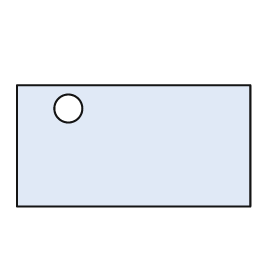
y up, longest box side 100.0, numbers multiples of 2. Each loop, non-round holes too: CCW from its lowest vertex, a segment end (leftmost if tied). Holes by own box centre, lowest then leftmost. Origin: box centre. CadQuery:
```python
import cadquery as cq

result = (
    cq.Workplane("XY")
    .moveTo(-50.0, -26.0)
    .lineTo(50.0, -26.0)
    .lineTo(50.0, 26.0)
    .lineTo(-50.0, 26.0)
    .close()
    .moveTo(-28.0, 16.0)
    .circle(6.0)
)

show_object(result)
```